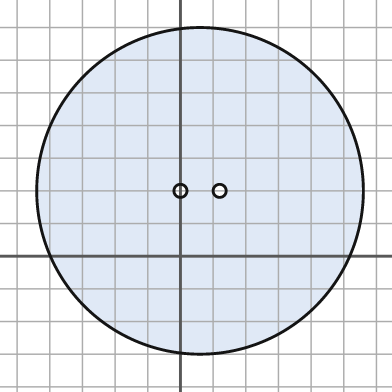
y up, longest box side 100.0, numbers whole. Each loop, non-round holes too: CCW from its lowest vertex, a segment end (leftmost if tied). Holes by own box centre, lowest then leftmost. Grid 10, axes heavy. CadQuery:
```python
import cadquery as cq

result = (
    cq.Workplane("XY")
    .moveTo(6.0, 20.0)
    .circle(50.0)
    .moveTo(0.0, 20.0)
    .circle(2.0)
    .moveTo(12.0, 20.0)
    .circle(2.0)
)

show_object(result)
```